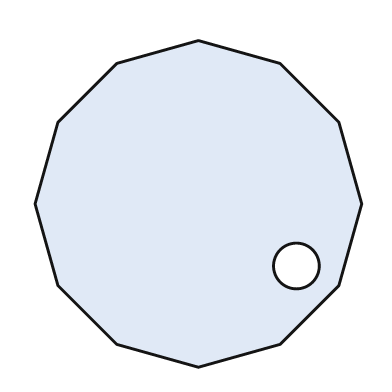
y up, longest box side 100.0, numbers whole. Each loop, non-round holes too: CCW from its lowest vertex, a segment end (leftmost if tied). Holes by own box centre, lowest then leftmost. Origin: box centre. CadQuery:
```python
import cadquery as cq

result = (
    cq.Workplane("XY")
    .moveTo(0.0, -50.0)
    .lineTo(25.0, -43.0)
    .lineTo(43.0, -25.0)
    .lineTo(50.0, 0.0)
    .lineTo(43.0, 25.0)
    .lineTo(25.0, 43.0)
    .lineTo(0.0, 50.0)
    .lineTo(-25.0, 43.0)
    .lineTo(-43.0, 25.0)
    .lineTo(-50.0, 0.0)
    .lineTo(-43.0, -25.0)
    .lineTo(-25.0, -43.0)
    .close()
    .moveTo(30.0, -19.0)
    .circle(7.0)
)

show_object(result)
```